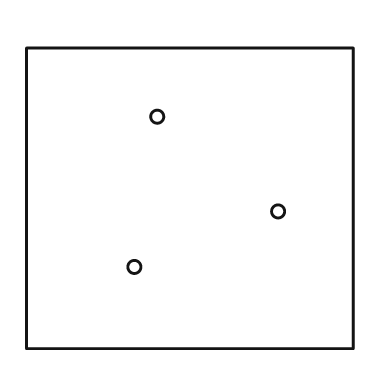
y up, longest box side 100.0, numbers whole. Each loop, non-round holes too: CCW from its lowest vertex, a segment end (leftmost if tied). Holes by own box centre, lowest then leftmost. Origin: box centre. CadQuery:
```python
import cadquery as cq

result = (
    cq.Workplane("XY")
    .moveTo(-50.0, -46.0)
    .lineTo(50.0, -46.0)
    .lineTo(50.0, 46.0)
    .lineTo(-50.0, 46.0)
    .close()
    .moveTo(-17.0, -21.0)
    .circle(2.0)
    .moveTo(27.0, -4.0)
    .circle(2.0)
    .moveTo(-10.0, 25.0)
    .circle(2.0)
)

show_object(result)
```